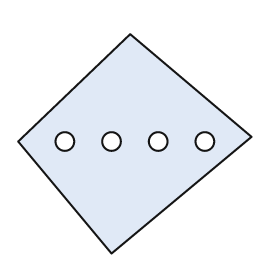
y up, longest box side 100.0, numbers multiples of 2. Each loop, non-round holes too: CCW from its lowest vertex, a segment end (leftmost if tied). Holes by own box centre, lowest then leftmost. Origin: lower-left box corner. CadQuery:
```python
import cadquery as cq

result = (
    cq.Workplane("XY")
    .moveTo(40.0, 0.0)
    .lineTo(100.0, 50.0)
    .lineTo(48.0, 94.0)
    .lineTo(0.0, 48.0)
    .close()
    .moveTo(20.0, 48.0)
    .circle(4.0)
    .moveTo(40.0, 48.0)
    .circle(4.0)
    .moveTo(60.0, 48.0)
    .circle(4.0)
    .moveTo(80.0, 48.0)
    .circle(4.0)
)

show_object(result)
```